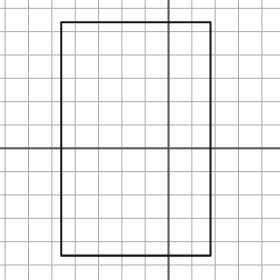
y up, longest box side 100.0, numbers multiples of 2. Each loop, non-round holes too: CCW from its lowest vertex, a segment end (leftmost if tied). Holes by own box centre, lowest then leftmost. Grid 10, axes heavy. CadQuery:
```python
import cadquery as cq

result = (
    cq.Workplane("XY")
    .moveTo(-46.0, -46.0)
    .lineTo(18.0, -46.0)
    .lineTo(18.0, 54.0)
    .lineTo(-46.0, 54.0)
    .close()
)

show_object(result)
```